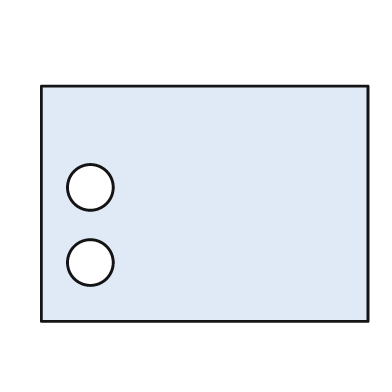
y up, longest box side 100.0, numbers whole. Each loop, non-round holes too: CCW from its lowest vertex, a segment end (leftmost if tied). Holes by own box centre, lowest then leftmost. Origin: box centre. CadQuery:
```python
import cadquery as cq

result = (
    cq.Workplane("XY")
    .moveTo(-50.0, -36.0)
    .lineTo(50.0, -36.0)
    .lineTo(50.0, 36.0)
    .lineTo(-50.0, 36.0)
    .close()
    .moveTo(-35.0, -18.0)
    .circle(7.0)
    .moveTo(-35.0, 5.0)
    .circle(7.0)
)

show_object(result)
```